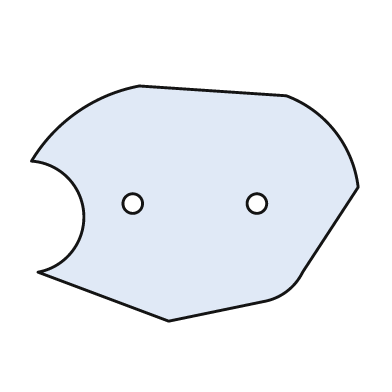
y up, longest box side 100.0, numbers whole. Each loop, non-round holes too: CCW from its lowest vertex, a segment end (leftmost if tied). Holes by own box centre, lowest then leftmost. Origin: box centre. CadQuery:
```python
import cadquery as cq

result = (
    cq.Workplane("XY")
    .moveTo(-8.0, -36.0)
    .lineTo(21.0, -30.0)
    .threePointArc((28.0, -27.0), (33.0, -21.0))
    .lineTo(50.0, 5.0)
    .threePointArc((43.0, 22.0), (28.0, 33.0))
    .lineTo(-17.0, 36.0)
    .threePointArc((-36.0, 28.0), (-50.0, 13.0))
    .threePointArc((-34.0, -3.0), (-48.0, -21.0))
    .close()
    .moveTo(-19.0, 0.0)
    .circle(3.0)
    .moveTo(19.0, 0.0)
    .circle(3.0)
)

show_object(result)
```